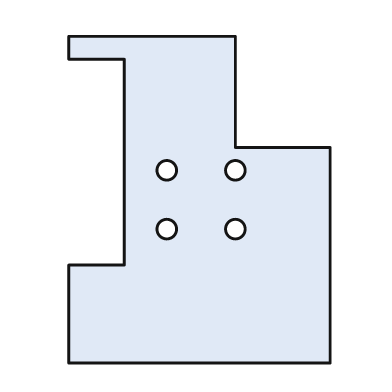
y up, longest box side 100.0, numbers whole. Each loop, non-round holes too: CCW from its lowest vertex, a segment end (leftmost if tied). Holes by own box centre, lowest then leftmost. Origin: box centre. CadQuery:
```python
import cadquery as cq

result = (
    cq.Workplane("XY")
    .moveTo(-40.0, -50.0)
    .lineTo(40.0, -50.0)
    .lineTo(40.0, 16.0)
    .lineTo(11.0, 16.0)
    .lineTo(11.0, 50.0)
    .lineTo(-40.0, 50.0)
    .lineTo(-40.0, 43.0)
    .lineTo(-23.0, 43.0)
    .lineTo(-23.0, -20.0)
    .lineTo(-40.0, -20.0)
    .close()
    .moveTo(-10.0, -9.0)
    .circle(3.0)
    .moveTo(11.0, -9.0)
    .circle(3.0)
    .moveTo(-10.0, 9.0)
    .circle(3.0)
    .moveTo(11.0, 9.0)
    .circle(3.0)
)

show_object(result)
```